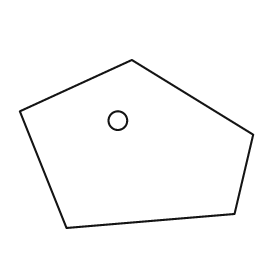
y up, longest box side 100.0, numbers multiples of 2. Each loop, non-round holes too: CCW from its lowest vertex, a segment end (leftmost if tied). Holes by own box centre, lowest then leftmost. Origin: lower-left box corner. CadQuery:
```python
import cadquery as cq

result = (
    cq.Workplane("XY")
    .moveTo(20.0, 0.0)
    .lineTo(92.0, 6.0)
    .lineTo(100.0, 40.0)
    .lineTo(48.0, 72.0)
    .lineTo(0.0, 50.0)
    .close()
    .moveTo(42.0, 46.0)
    .circle(4.0)
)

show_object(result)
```